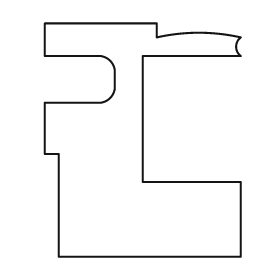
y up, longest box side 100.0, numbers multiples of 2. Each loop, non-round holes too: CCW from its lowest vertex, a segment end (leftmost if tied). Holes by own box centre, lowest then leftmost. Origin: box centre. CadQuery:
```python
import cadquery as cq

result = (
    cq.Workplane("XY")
    .moveTo(-36.0, -50.0)
    .lineTo(42.0, -50.0)
    .lineTo(42.0, -18.0)
    .lineTo(0.0, -18.0)
    .lineTo(0.0, 36.0)
    .lineTo(42.0, 36.0)
    .threePointArc((40.0, 40.0), (42.0, 44.0))
    .threePointArc((24.0, 46.0), (6.0, 44.0))
    .lineTo(6.0, 50.0)
    .lineTo(-42.0, 50.0)
    .lineTo(-42.0, 36.0)
    .lineTo(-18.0, 36.0)
    .threePointArc((-14.0, 34.0), (-12.0, 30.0))
    .lineTo(-12.0, 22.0)
    .threePointArc((-14.0, 18.0), (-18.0, 16.0))
    .lineTo(-42.0, 16.0)
    .lineTo(-42.0, -6.0)
    .lineTo(-36.0, -6.0)
    .close()
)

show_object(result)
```